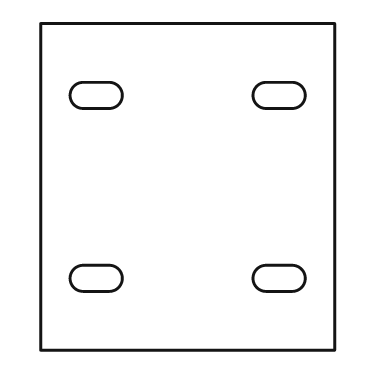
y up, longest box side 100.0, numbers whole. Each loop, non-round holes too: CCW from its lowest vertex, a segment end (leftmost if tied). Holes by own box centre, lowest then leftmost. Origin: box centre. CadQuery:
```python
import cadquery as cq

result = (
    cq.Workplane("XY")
    .moveTo(-45.0, -50.0)
    .lineTo(45.0, -50.0)
    .lineTo(45.0, 50.0)
    .lineTo(-45.0, 50.0)
    .close()
    .moveTo(-32.0, -32.0)
    .lineTo(-24.0, -32.0)
    .threePointArc((-20.0, -28.0), (-24.0, -24.0))
    .lineTo(-32.0, -24.0)
    .threePointArc((-36.0, -28.0), (-32.0, -32.0))
    .close()
    .moveTo(24.0, -32.0)
    .lineTo(32.0, -32.0)
    .threePointArc((36.0, -28.0), (32.0, -24.0))
    .lineTo(24.0, -24.0)
    .threePointArc((20.0, -28.0), (24.0, -32.0))
    .close()
    .moveTo(-32.0, 24.0)
    .lineTo(-24.0, 24.0)
    .threePointArc((-20.0, 28.0), (-24.0, 32.0))
    .lineTo(-32.0, 32.0)
    .threePointArc((-36.0, 28.0), (-32.0, 24.0))
    .close()
    .moveTo(24.0, 24.0)
    .lineTo(32.0, 24.0)
    .threePointArc((36.0, 28.0), (32.0, 32.0))
    .lineTo(24.0, 32.0)
    .threePointArc((20.0, 28.0), (24.0, 24.0))
    .close()
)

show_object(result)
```